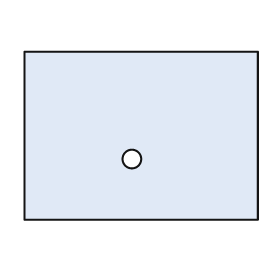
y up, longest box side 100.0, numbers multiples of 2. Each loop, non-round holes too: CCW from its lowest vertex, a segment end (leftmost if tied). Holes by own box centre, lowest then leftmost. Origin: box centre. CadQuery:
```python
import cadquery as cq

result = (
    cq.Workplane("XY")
    .moveTo(-50.0, -36.0)
    .lineTo(50.0, -36.0)
    .lineTo(50.0, 36.0)
    .lineTo(-50.0, 36.0)
    .close()
    .moveTo(-4.0, -10.0)
    .circle(4.0)
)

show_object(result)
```